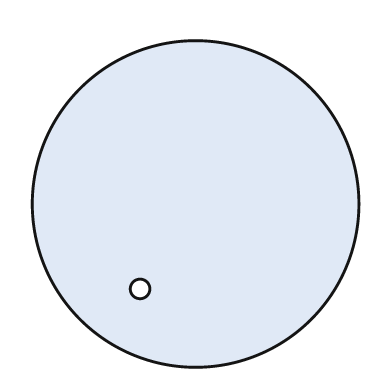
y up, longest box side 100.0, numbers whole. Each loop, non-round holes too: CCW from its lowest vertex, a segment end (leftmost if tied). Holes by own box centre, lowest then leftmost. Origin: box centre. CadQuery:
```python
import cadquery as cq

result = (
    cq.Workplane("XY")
    .moveTo(0.0, 0.0)
    .circle(50.0)
    .moveTo(-17.0, -26.0)
    .circle(3.0)
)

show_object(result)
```